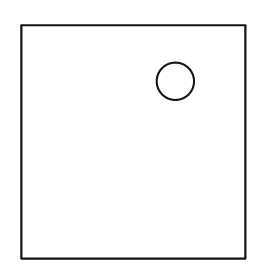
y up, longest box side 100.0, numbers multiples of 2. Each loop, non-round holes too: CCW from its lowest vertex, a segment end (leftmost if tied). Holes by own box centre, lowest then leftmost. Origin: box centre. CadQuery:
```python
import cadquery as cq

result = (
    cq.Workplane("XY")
    .moveTo(-48.0, -50.0)
    .lineTo(48.0, -50.0)
    .lineTo(48.0, 50.0)
    .lineTo(-48.0, 50.0)
    .close()
    .moveTo(18.0, 26.0)
    .circle(8.0)
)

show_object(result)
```